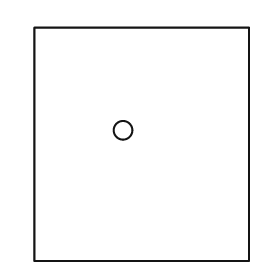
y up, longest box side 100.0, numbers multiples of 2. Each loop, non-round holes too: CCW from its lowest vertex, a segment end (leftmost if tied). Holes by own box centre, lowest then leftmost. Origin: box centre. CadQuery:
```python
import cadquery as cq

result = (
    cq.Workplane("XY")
    .moveTo(-46.0, -50.0)
    .lineTo(46.0, -50.0)
    .lineTo(46.0, 50.0)
    .lineTo(-46.0, 50.0)
    .close()
    .moveTo(-8.0, 6.0)
    .circle(4.0)
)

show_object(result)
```